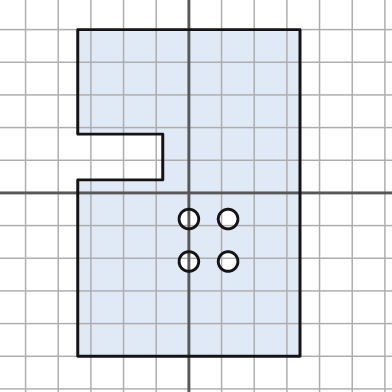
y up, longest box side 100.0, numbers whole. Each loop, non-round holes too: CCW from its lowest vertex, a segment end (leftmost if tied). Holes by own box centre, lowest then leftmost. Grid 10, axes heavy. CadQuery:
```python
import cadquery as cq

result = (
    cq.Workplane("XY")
    .moveTo(-34.0, -50.0)
    .lineTo(34.0, -50.0)
    .lineTo(34.0, 50.0)
    .lineTo(-34.0, 50.0)
    .lineTo(-34.0, 18.0)
    .lineTo(-8.0, 18.0)
    .lineTo(-8.0, 4.0)
    .lineTo(-34.0, 4.0)
    .close()
    .moveTo(0.0, -21.0)
    .circle(3.0)
    .moveTo(12.0, -21.0)
    .circle(3.0)
    .moveTo(0.0, -8.0)
    .circle(3.0)
    .moveTo(12.0, -8.0)
    .circle(3.0)
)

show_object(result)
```